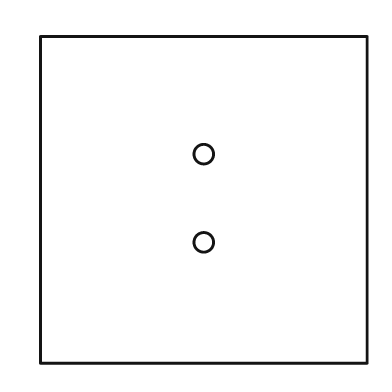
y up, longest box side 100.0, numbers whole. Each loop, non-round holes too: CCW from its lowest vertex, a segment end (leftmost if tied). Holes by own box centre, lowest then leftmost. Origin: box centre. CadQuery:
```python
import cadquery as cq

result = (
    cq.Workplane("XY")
    .moveTo(-50.0, -50.0)
    .lineTo(50.0, -50.0)
    .lineTo(50.0, 50.0)
    .lineTo(-50.0, 50.0)
    .close()
    .moveTo(0.0, -13.0)
    .circle(3.0)
    .moveTo(0.0, 14.0)
    .circle(3.0)
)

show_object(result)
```